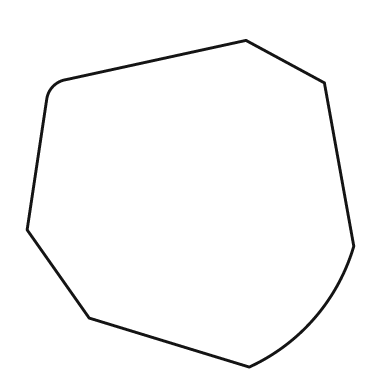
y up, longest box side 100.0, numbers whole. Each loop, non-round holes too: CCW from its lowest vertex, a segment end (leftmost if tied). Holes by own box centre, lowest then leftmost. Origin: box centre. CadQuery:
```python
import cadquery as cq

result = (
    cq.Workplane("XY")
    .moveTo(18.0, -50.0)
    .threePointArc((38.0, -35.0), (50.0, -13.0))
    .lineTo(41.0, 37.0)
    .lineTo(17.0, 50.0)
    .lineTo(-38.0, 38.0)
    .threePointArc((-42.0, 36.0), (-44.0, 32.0))
    .lineTo(-50.0, -8.0)
    .lineTo(-31.0, -35.0)
    .close()
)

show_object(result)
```